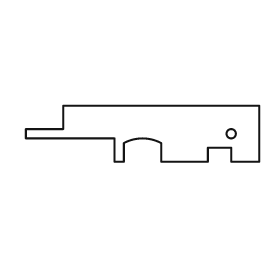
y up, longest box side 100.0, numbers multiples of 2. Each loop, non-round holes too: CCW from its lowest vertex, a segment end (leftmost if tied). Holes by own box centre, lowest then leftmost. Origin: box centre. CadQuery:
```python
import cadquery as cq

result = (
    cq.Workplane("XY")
    .moveTo(-12.0, -12.0)
    .lineTo(-8.0, -12.0)
    .lineTo(-8.0, -4.0)
    .threePointArc((0.0, -2.0), (8.0, -4.0))
    .lineTo(8.0, -12.0)
    .lineTo(28.0, -12.0)
    .lineTo(28.0, -6.0)
    .lineTo(38.0, -6.0)
    .lineTo(38.0, -12.0)
    .lineTo(50.0, -12.0)
    .lineTo(50.0, 12.0)
    .lineTo(-34.0, 12.0)
    .lineTo(-34.0, 2.0)
    .lineTo(-50.0, 2.0)
    .lineTo(-50.0, -2.0)
    .lineTo(-12.0, -2.0)
    .close()
    .moveTo(38.0, 0.0)
    .circle(2.0)
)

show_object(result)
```